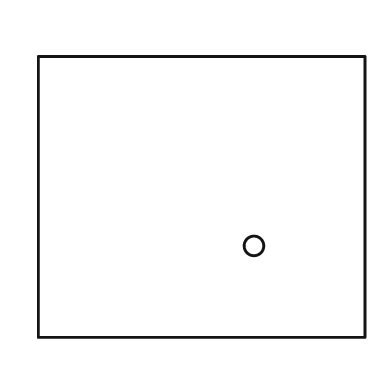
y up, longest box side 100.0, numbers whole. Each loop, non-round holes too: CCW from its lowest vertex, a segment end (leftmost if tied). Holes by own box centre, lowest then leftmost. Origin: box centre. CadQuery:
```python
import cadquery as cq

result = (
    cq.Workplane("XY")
    .moveTo(-50.0, -43.0)
    .lineTo(50.0, -43.0)
    .lineTo(50.0, 43.0)
    .lineTo(-50.0, 43.0)
    .close()
    .moveTo(16.0, -15.0)
    .circle(3.0)
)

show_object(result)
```